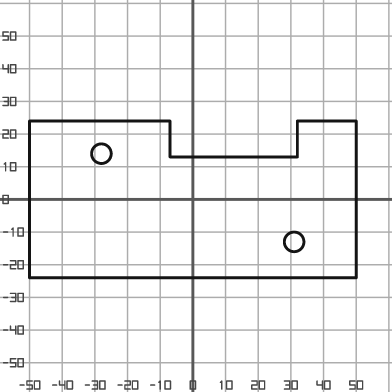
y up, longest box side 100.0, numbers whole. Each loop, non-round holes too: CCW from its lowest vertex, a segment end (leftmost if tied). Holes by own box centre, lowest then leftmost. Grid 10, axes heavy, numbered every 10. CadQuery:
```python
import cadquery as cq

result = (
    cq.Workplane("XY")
    .moveTo(-50.0, -24.0)
    .lineTo(50.0, -24.0)
    .lineTo(50.0, 24.0)
    .lineTo(32.0, 24.0)
    .lineTo(32.0, 13.0)
    .lineTo(-7.0, 13.0)
    .lineTo(-7.0, 24.0)
    .lineTo(-50.0, 24.0)
    .close()
    .moveTo(31.0, -13.0)
    .circle(3.0)
    .moveTo(-28.0, 14.0)
    .circle(3.0)
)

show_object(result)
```